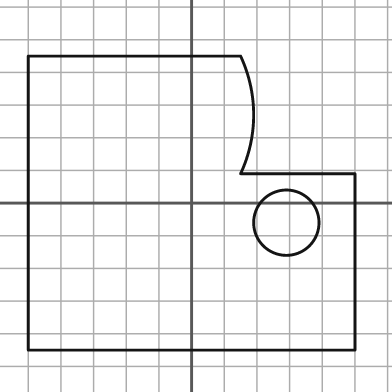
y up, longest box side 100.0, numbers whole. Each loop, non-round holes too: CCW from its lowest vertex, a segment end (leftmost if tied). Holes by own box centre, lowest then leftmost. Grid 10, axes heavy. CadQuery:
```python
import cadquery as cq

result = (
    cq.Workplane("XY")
    .moveTo(-50.0, -45.0)
    .lineTo(50.0, -45.0)
    .lineTo(50.0, 9.0)
    .lineTo(15.0, 9.0)
    .threePointArc((19.0, 27.0), (15.0, 45.0))
    .lineTo(-50.0, 45.0)
    .close()
    .moveTo(29.0, -6.0)
    .circle(10.0)
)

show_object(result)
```